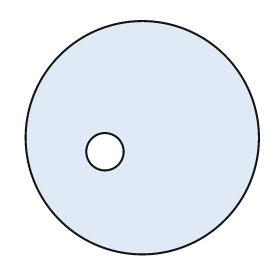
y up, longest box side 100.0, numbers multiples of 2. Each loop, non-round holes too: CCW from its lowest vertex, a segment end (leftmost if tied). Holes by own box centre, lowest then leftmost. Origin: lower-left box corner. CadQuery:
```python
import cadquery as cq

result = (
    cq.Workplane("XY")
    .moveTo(50.0, 50.0)
    .circle(50.0)
    .moveTo(34.0, 44.0)
    .circle(8.0)
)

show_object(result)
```